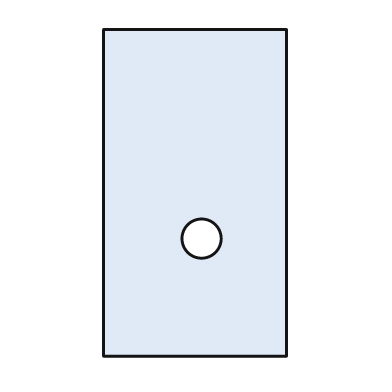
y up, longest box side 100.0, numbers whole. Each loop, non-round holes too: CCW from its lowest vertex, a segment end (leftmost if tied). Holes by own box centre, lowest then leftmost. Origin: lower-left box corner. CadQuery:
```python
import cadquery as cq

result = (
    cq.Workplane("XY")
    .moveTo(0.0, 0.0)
    .lineTo(56.0, 0.0)
    .lineTo(56.0, 100.0)
    .lineTo(0.0, 100.0)
    .close()
    .moveTo(30.0, 36.0)
    .circle(6.0)
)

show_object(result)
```